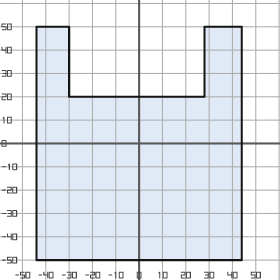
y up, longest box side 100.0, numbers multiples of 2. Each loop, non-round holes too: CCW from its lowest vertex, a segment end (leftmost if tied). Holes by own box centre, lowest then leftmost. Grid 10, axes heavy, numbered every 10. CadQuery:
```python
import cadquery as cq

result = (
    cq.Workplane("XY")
    .moveTo(-44.0, -50.0)
    .lineTo(44.0, -50.0)
    .lineTo(44.0, 50.0)
    .lineTo(28.0, 50.0)
    .lineTo(28.0, 20.0)
    .lineTo(-30.0, 20.0)
    .lineTo(-30.0, 50.0)
    .lineTo(-44.0, 50.0)
    .close()
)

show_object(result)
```